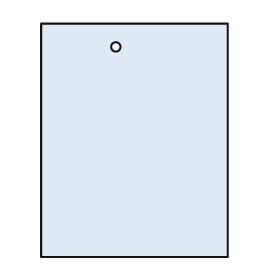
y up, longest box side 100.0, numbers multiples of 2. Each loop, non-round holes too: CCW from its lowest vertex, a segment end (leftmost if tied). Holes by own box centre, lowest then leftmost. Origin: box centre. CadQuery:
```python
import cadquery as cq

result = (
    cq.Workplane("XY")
    .moveTo(-40.0, -50.0)
    .lineTo(40.0, -50.0)
    .lineTo(40.0, 50.0)
    .lineTo(-40.0, 50.0)
    .close()
    .moveTo(-8.0, 40.0)
    .circle(2.0)
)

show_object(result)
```